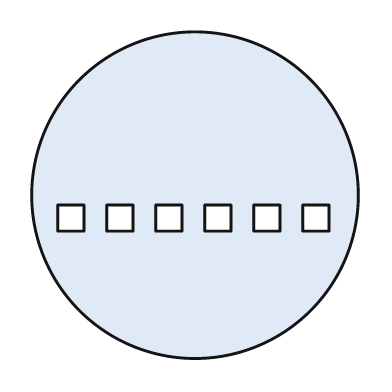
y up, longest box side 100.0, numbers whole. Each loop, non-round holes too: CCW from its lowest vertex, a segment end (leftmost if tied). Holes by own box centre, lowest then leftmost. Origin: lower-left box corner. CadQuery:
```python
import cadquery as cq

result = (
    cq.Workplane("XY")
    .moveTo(50.0, 50.0)
    .circle(50.0)
    .moveTo(8.0, 39.0)
    .lineTo(16.0, 39.0)
    .lineTo(16.0, 47.0)
    .lineTo(8.0, 47.0)
    .close()
    .moveTo(23.0, 39.0)
    .lineTo(31.0, 39.0)
    .lineTo(31.0, 47.0)
    .lineTo(23.0, 47.0)
    .close()
    .moveTo(38.0, 39.0)
    .lineTo(46.0, 39.0)
    .lineTo(46.0, 47.0)
    .lineTo(38.0, 47.0)
    .close()
    .moveTo(53.0, 39.0)
    .lineTo(61.0, 39.0)
    .lineTo(61.0, 47.0)
    .lineTo(53.0, 47.0)
    .close()
    .moveTo(68.0, 39.0)
    .lineTo(76.0, 39.0)
    .lineTo(76.0, 47.0)
    .lineTo(68.0, 47.0)
    .close()
    .moveTo(83.0, 39.0)
    .lineTo(91.0, 39.0)
    .lineTo(91.0, 47.0)
    .lineTo(83.0, 47.0)
    .close()
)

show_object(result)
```